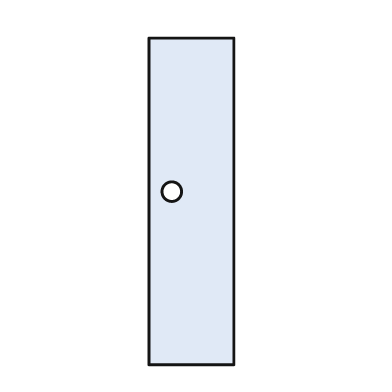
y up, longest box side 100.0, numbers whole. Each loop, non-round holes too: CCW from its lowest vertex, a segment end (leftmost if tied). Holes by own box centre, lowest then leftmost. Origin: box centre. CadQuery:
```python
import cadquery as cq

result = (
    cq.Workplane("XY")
    .moveTo(-13.0, -50.0)
    .lineTo(13.0, -50.0)
    .lineTo(13.0, 50.0)
    .lineTo(-13.0, 50.0)
    .close()
    .moveTo(-6.0, 3.0)
    .circle(3.0)
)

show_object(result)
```